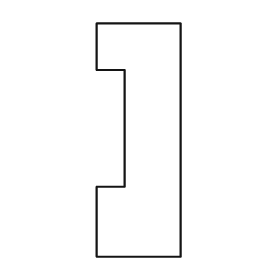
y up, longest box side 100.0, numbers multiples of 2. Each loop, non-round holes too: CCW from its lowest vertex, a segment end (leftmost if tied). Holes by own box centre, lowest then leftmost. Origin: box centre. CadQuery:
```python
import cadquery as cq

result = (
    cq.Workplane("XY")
    .moveTo(-18.0, -50.0)
    .lineTo(18.0, -50.0)
    .lineTo(18.0, 50.0)
    .lineTo(-18.0, 50.0)
    .lineTo(-18.0, 30.0)
    .lineTo(-6.0, 30.0)
    .lineTo(-6.0, -20.0)
    .lineTo(-18.0, -20.0)
    .close()
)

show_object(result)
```